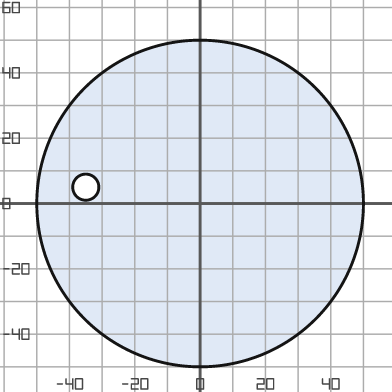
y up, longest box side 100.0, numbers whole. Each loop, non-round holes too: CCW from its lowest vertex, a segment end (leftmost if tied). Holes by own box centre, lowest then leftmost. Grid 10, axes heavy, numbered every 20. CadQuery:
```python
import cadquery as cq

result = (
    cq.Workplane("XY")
    .moveTo(0.0, 0.0)
    .circle(50.0)
    .moveTo(-35.0, 5.0)
    .circle(4.0)
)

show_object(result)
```